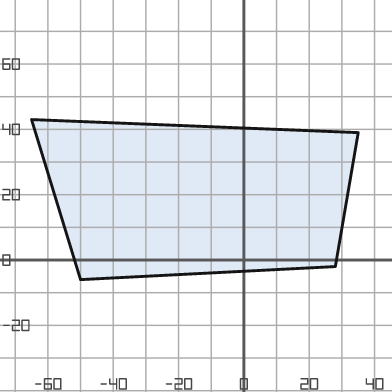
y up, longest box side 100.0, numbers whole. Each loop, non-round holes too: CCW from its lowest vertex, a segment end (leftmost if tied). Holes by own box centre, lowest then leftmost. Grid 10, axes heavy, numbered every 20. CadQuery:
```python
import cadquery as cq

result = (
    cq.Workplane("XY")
    .moveTo(-50.0, -6.0)
    .lineTo(28.0, -2.0)
    .lineTo(35.0, 39.0)
    .lineTo(-65.0, 43.0)
    .close()
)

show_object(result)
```